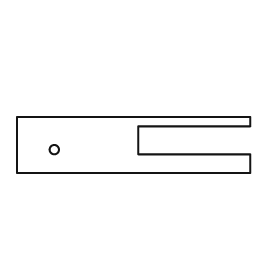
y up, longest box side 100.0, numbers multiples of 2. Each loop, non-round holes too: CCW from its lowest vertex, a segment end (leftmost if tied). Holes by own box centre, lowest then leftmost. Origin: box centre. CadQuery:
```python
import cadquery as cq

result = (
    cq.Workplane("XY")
    .moveTo(-50.0, -12.0)
    .lineTo(50.0, -12.0)
    .lineTo(50.0, -4.0)
    .lineTo(2.0, -4.0)
    .lineTo(2.0, 8.0)
    .lineTo(50.0, 8.0)
    .lineTo(50.0, 12.0)
    .lineTo(-50.0, 12.0)
    .close()
    .moveTo(-34.0, -2.0)
    .circle(2.0)
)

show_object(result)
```